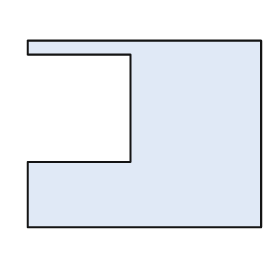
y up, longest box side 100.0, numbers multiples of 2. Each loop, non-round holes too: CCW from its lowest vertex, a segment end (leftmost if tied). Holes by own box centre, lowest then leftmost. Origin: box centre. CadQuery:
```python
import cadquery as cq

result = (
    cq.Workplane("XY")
    .moveTo(-50.0, -40.0)
    .lineTo(50.0, -40.0)
    .lineTo(50.0, 40.0)
    .lineTo(-50.0, 40.0)
    .lineTo(-50.0, 34.0)
    .lineTo(-6.0, 34.0)
    .lineTo(-6.0, -12.0)
    .lineTo(-50.0, -12.0)
    .close()
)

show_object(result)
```